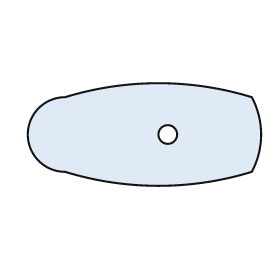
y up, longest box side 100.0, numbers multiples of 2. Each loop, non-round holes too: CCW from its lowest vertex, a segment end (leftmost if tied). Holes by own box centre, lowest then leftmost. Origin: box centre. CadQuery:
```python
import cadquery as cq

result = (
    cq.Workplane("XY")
    .moveTo(-34.0, -16.0)
    .threePointArc((6.0, -22.0), (46.0, -16.0))
    .threePointArc((50.0, 0.0), (46.0, 16.0))
    .threePointArc((6.0, 22.0), (-34.0, 16.0))
    .threePointArc((-50.0, 0.0), (-34.0, -16.0))
    .close()
    .moveTo(10.0, 0.0)
    .circle(4.0)
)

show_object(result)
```